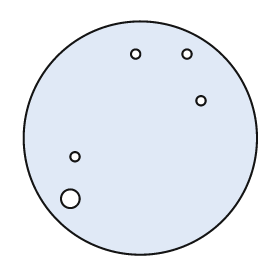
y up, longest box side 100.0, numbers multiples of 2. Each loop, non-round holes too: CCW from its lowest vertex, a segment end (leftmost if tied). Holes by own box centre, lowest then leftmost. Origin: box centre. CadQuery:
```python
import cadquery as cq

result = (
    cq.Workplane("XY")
    .moveTo(0.0, 0.0)
    .circle(50.0)
    .moveTo(-30.0, -26.0)
    .circle(4.0)
    .moveTo(-28.0, -8.0)
    .circle(2.0)
    .moveTo(26.0, 16.0)
    .circle(2.0)
    .moveTo(-2.0, 36.0)
    .circle(2.0)
    .moveTo(20.0, 36.0)
    .circle(2.0)
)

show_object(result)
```